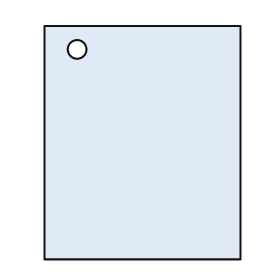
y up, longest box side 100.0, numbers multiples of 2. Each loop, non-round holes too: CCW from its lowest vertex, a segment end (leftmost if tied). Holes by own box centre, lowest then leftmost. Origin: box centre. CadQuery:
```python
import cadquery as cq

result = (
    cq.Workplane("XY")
    .moveTo(-42.0, -50.0)
    .lineTo(42.0, -50.0)
    .lineTo(42.0, 50.0)
    .lineTo(-42.0, 50.0)
    .close()
    .moveTo(-28.0, 40.0)
    .circle(4.0)
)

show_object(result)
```